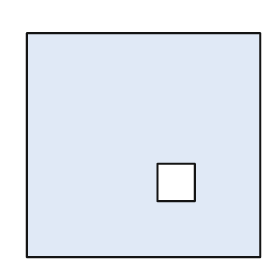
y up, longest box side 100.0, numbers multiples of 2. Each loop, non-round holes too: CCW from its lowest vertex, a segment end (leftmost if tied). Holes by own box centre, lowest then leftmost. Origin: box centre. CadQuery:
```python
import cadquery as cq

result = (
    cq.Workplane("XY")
    .moveTo(-50.0, -48.0)
    .lineTo(50.0, -48.0)
    .lineTo(50.0, 48.0)
    .lineTo(-50.0, 48.0)
    .close()
    .moveTo(6.0, -24.0)
    .lineTo(22.0, -24.0)
    .lineTo(22.0, -8.0)
    .lineTo(6.0, -8.0)
    .close()
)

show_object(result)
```